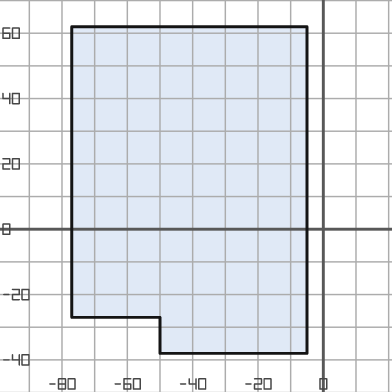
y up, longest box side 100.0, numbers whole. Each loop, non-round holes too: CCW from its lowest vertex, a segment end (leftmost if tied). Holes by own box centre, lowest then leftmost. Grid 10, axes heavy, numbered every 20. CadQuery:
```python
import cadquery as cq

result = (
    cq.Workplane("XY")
    .moveTo(-50.0, -38.0)
    .lineTo(-5.0, -38.0)
    .lineTo(-5.0, 62.0)
    .lineTo(-77.0, 62.0)
    .lineTo(-77.0, -27.0)
    .lineTo(-50.0, -27.0)
    .close()
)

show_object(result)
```